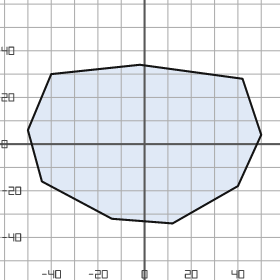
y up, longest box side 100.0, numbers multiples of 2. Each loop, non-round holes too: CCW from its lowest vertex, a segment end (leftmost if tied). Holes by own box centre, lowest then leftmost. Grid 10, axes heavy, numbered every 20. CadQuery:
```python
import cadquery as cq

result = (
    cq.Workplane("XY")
    .moveTo(12.0, -34.0)
    .lineTo(40.0, -18.0)
    .lineTo(50.0, 4.0)
    .lineTo(42.0, 28.0)
    .lineTo(-2.0, 34.0)
    .lineTo(-40.0, 30.0)
    .lineTo(-50.0, 6.0)
    .lineTo(-44.0, -16.0)
    .lineTo(-14.0, -32.0)
    .close()
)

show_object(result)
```